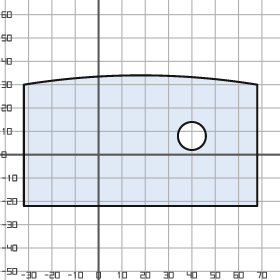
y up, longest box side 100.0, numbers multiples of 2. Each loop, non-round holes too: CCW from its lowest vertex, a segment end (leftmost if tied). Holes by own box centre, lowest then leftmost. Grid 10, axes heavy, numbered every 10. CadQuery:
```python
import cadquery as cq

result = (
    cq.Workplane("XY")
    .moveTo(-32.0, -22.0)
    .lineTo(68.0, -22.0)
    .lineTo(68.0, 30.0)
    .threePointArc((18.0, 34.0), (-32.0, 30.0))
    .close()
    .moveTo(40.0, 8.0)
    .circle(6.0)
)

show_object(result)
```